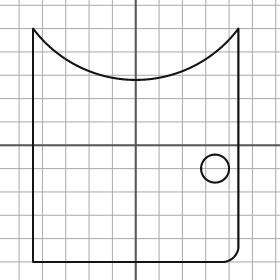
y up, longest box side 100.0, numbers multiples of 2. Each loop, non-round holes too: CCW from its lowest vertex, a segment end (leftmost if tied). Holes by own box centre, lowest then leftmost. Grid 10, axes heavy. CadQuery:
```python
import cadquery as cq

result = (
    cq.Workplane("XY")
    .moveTo(-44.0, -50.0)
    .lineTo(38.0, -50.0)
    .threePointArc((42.0, -48.0), (44.0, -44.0))
    .lineTo(44.0, 50.0)
    .threePointArc((0.0, 28.0), (-44.0, 50.0))
    .close()
    .moveTo(34.0, -10.0)
    .circle(6.0)
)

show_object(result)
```